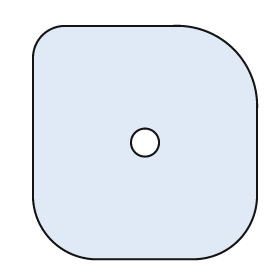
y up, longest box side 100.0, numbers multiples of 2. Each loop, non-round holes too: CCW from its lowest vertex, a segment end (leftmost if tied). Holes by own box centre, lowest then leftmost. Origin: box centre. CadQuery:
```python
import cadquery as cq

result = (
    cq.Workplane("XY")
    .moveTo(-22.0, -50.0)
    .lineTo(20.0, -50.0)
    .threePointArc((40.0, -42.0), (48.0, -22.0))
    .lineTo(48.0, 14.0)
    .threePointArc((38.0, 40.0), (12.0, 50.0))
    .lineTo(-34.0, 50.0)
    .threePointArc((-44.0, 46.0), (-48.0, 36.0))
    .lineTo(-48.0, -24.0)
    .threePointArc((-40.0, -42.0), (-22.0, -50.0))
    .close()
    .moveTo(0.0, 0.0)
    .circle(6.0)
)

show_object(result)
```